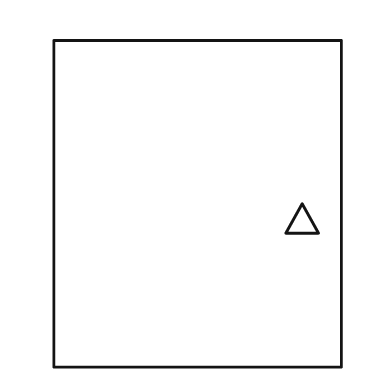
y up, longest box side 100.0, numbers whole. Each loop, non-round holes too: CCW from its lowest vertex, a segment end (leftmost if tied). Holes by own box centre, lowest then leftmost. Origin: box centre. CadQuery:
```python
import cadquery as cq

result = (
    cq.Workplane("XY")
    .moveTo(-44.0, -50.0)
    .lineTo(44.0, -50.0)
    .lineTo(44.0, 50.0)
    .lineTo(-44.0, 50.0)
    .close()
    .moveTo(27.0, -9.0)
    .lineTo(37.0, -9.0)
    .lineTo(32.0, 0.0)
    .close()
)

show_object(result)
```